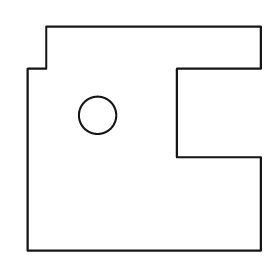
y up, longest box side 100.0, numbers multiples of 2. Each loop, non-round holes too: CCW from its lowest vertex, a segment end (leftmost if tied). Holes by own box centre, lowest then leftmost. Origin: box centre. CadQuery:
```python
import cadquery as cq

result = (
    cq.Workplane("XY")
    .moveTo(-50.0, -48.0)
    .lineTo(50.0, -48.0)
    .lineTo(50.0, -8.0)
    .lineTo(14.0, -8.0)
    .lineTo(14.0, 30.0)
    .lineTo(50.0, 30.0)
    .lineTo(50.0, 48.0)
    .lineTo(-42.0, 48.0)
    .lineTo(-42.0, 30.0)
    .lineTo(-50.0, 30.0)
    .close()
    .moveTo(-20.0, 10.0)
    .circle(8.0)
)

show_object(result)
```